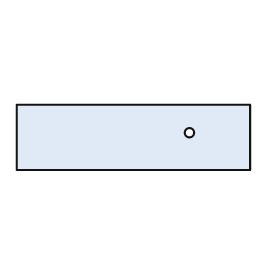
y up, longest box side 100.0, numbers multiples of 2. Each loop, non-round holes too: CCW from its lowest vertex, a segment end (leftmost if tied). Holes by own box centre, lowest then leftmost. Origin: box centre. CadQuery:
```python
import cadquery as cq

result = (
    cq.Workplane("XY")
    .moveTo(-50.0, -14.0)
    .lineTo(50.0, -14.0)
    .lineTo(50.0, 14.0)
    .lineTo(-50.0, 14.0)
    .close()
    .moveTo(24.0, 2.0)
    .circle(2.0)
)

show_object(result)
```